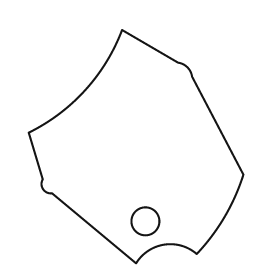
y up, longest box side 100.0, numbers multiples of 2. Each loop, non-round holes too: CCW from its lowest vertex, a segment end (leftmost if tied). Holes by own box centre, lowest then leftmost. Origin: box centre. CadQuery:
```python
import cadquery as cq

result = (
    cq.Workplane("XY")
    .moveTo(0.0, -50.0)
    .threePointArc((12.0, -42.0), (26.0, -46.0))
    .threePointArc((38.0, -30.0), (46.0, -12.0))
    .lineTo(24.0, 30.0)
    .threePointArc((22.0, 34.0), (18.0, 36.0))
    .lineTo(-6.0, 50.0)
    .threePointArc((-22.0, 24.0), (-46.0, 6.0))
    .lineTo(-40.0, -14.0)
    .threePointArc((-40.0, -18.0), (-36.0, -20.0))
    .close()
    .moveTo(4.0, -32.0)
    .circle(6.0)
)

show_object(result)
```